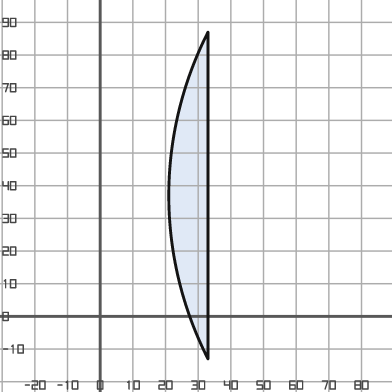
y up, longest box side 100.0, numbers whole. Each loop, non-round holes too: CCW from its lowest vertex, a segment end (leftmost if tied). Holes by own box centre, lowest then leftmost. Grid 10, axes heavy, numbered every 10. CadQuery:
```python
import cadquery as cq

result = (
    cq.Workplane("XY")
    .moveTo(33.0, -13.0)
    .lineTo(33.0, 87.0)
    .threePointArc((21.0, 37.0), (33.0, -13.0))
    .close()
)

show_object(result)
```